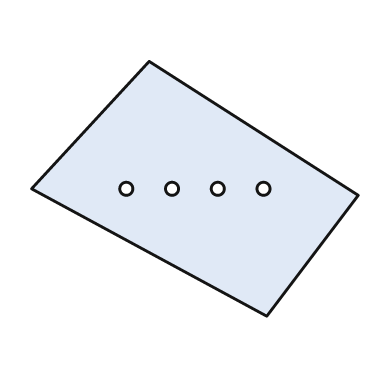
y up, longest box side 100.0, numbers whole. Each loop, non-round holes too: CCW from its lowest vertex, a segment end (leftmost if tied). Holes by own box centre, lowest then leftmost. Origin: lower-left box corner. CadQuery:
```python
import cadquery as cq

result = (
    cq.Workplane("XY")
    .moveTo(72.0, 0.0)
    .lineTo(100.0, 37.0)
    .lineTo(36.0, 78.0)
    .lineTo(0.0, 39.0)
    .close()
    .moveTo(29.0, 39.0)
    .circle(2.0)
    .moveTo(43.0, 39.0)
    .circle(2.0)
    .moveTo(57.0, 39.0)
    .circle(2.0)
    .moveTo(71.0, 39.0)
    .circle(2.0)
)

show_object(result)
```